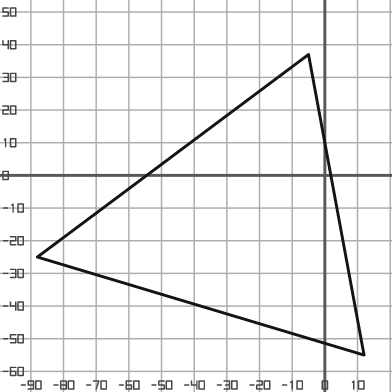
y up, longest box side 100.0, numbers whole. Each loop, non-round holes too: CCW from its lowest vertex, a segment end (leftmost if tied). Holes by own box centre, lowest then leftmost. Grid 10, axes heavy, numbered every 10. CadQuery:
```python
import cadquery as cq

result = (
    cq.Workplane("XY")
    .moveTo(12.0, -55.0)
    .lineTo(-5.0, 37.0)
    .lineTo(-88.0, -25.0)
    .close()
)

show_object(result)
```